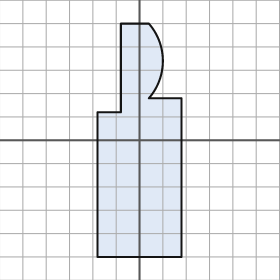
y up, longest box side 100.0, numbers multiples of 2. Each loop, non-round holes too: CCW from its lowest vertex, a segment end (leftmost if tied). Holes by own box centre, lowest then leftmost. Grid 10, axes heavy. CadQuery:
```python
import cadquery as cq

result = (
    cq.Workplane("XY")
    .moveTo(-18.0, -50.0)
    .lineTo(18.0, -50.0)
    .lineTo(18.0, 18.0)
    .lineTo(4.0, 18.0)
    .threePointArc((10.0, 34.0), (4.0, 50.0))
    .lineTo(-8.0, 50.0)
    .lineTo(-8.0, 12.0)
    .lineTo(-18.0, 12.0)
    .close()
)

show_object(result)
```